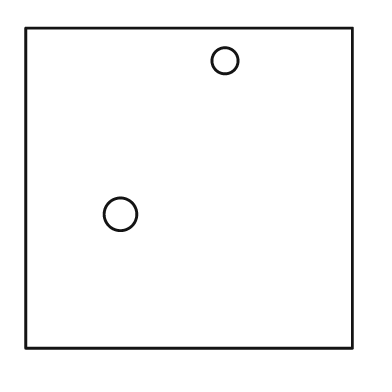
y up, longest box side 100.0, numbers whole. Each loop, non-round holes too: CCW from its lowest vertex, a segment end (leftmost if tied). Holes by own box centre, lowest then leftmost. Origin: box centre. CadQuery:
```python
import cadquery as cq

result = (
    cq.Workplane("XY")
    .moveTo(-50.0, -49.0)
    .lineTo(50.0, -49.0)
    .lineTo(50.0, 49.0)
    .lineTo(-50.0, 49.0)
    .close()
    .moveTo(-21.0, -8.0)
    .circle(5.0)
    .moveTo(11.0, 39.0)
    .circle(4.0)
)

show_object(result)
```